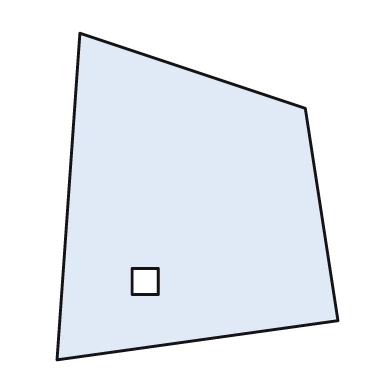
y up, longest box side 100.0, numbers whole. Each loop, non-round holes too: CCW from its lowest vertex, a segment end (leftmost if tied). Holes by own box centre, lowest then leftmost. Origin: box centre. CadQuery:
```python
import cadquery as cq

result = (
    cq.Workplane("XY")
    .moveTo(-43.0, -50.0)
    .lineTo(43.0, -38.0)
    .lineTo(33.0, 27.0)
    .lineTo(-36.0, 50.0)
    .close()
    .moveTo(-20.0, -30.0)
    .lineTo(-12.0, -30.0)
    .lineTo(-12.0, -22.0)
    .lineTo(-20.0, -22.0)
    .close()
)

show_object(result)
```